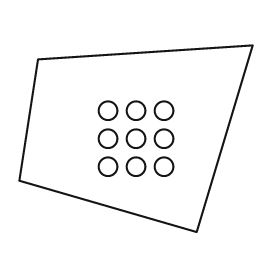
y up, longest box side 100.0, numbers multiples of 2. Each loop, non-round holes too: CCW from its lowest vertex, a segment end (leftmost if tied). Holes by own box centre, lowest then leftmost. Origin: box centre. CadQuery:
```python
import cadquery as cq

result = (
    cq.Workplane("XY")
    .moveTo(26.0, -40.0)
    .lineTo(50.0, 40.0)
    .lineTo(-42.0, 34.0)
    .lineTo(-50.0, -18.0)
    .close()
    .moveTo(-12.0, -12.0)
    .circle(4.0)
    .moveTo(0.0, -12.0)
    .circle(4.0)
    .moveTo(12.0, -12.0)
    .circle(4.0)
    .moveTo(-12.0, 0.0)
    .circle(4.0)
    .moveTo(0.0, 0.0)
    .circle(4.0)
    .moveTo(12.0, 0.0)
    .circle(4.0)
    .moveTo(-12.0, 12.0)
    .circle(4.0)
    .moveTo(0.0, 12.0)
    .circle(4.0)
    .moveTo(12.0, 12.0)
    .circle(4.0)
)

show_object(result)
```